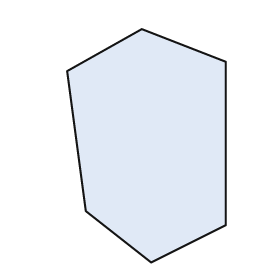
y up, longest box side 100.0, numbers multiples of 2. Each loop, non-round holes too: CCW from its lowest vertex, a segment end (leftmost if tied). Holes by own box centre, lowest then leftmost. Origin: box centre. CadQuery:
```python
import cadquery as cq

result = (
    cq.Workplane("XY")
    .moveTo(2.0, -50.0)
    .lineTo(34.0, -34.0)
    .lineTo(34.0, 36.0)
    .lineTo(-2.0, 50.0)
    .lineTo(-34.0, 32.0)
    .lineTo(-26.0, -28.0)
    .close()
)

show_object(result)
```